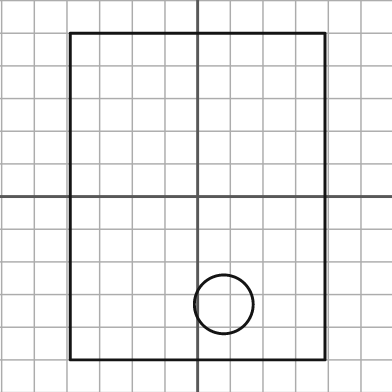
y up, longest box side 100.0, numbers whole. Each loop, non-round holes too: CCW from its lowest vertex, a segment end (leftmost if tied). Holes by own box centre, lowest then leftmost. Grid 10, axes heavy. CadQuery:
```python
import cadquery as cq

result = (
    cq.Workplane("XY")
    .moveTo(-39.0, -50.0)
    .lineTo(39.0, -50.0)
    .lineTo(39.0, 50.0)
    .lineTo(-39.0, 50.0)
    .close()
    .moveTo(8.0, -33.0)
    .circle(9.0)
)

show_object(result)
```